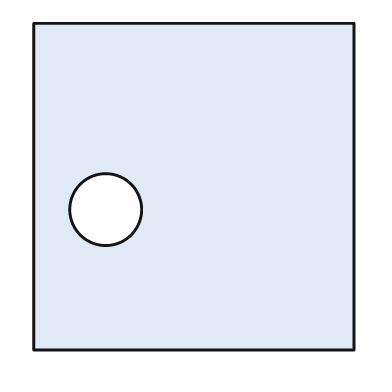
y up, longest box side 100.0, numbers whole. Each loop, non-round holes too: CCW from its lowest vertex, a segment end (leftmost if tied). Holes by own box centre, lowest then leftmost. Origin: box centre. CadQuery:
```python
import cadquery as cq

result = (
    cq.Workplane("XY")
    .moveTo(-49.0, -50.0)
    .lineTo(49.0, -50.0)
    .lineTo(49.0, 50.0)
    .lineTo(-49.0, 50.0)
    .close()
    .moveTo(-27.0, -7.0)
    .circle(11.0)
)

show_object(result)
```